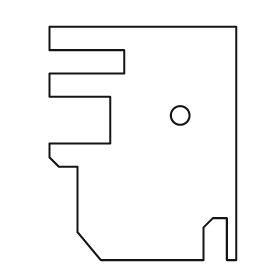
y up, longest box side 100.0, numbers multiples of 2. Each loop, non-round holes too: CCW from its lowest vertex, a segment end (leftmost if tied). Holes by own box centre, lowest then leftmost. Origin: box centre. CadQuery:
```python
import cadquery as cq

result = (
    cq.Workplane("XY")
    .moveTo(-18.0, -50.0)
    .lineTo(26.0, -50.0)
    .lineTo(26.0, -36.0)
    .lineTo(30.0, -32.0)
    .lineTo(36.0, -32.0)
    .lineTo(36.0, -50.0)
    .lineTo(40.0, -50.0)
    .lineTo(40.0, 50.0)
    .lineTo(-40.0, 50.0)
    .lineTo(-40.0, 40.0)
    .lineTo(-8.0, 40.0)
    .lineTo(-8.0, 30.0)
    .lineTo(-40.0, 30.0)
    .lineTo(-40.0, 20.0)
    .lineTo(-14.0, 20.0)
    .lineTo(-14.0, 0.0)
    .lineTo(-40.0, 0.0)
    .lineTo(-40.0, -6.0)
    .lineTo(-36.0, -10.0)
    .lineTo(-28.0, -10.0)
    .lineTo(-28.0, -38.0)
    .close()
    .moveTo(16.0, 12.0)
    .circle(4.0)
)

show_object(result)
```